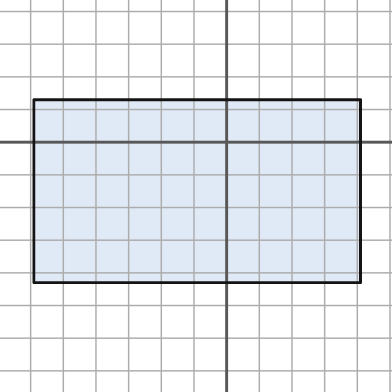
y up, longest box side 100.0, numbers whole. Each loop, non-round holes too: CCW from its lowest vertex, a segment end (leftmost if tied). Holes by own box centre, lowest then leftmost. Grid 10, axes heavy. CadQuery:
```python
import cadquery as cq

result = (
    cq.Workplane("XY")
    .moveTo(-59.0, -43.0)
    .lineTo(41.0, -43.0)
    .lineTo(41.0, 13.0)
    .lineTo(-59.0, 13.0)
    .close()
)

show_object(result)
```